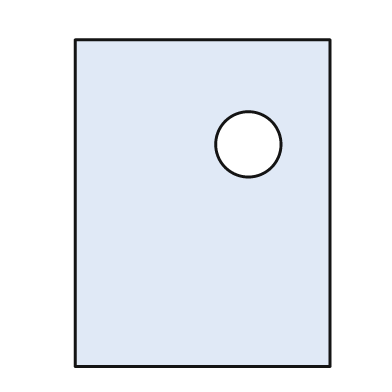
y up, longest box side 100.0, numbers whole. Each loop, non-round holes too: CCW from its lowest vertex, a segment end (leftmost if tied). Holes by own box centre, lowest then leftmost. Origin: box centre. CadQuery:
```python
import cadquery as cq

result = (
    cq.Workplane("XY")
    .moveTo(-39.0, -50.0)
    .lineTo(39.0, -50.0)
    .lineTo(39.0, 50.0)
    .lineTo(-39.0, 50.0)
    .close()
    .moveTo(14.0, 18.0)
    .circle(10.0)
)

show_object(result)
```